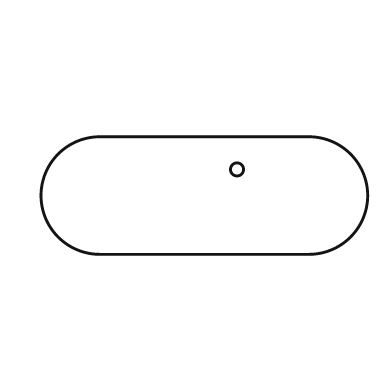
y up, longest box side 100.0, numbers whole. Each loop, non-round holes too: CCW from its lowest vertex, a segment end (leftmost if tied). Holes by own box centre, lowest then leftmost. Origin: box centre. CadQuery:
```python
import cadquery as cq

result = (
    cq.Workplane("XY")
    .moveTo(-32.0, -18.0)
    .lineTo(32.0, -18.0)
    .threePointArc((50.0, 0.0), (32.0, 18.0))
    .lineTo(-32.0, 18.0)
    .threePointArc((-50.0, 0.0), (-32.0, -18.0))
    .close()
    .moveTo(10.0, 8.0)
    .circle(2.0)
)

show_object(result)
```